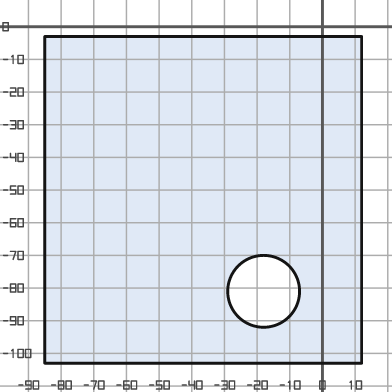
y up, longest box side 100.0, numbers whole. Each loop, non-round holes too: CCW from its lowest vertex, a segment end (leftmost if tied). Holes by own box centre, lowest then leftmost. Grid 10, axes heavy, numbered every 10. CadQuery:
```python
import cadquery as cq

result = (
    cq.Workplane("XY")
    .moveTo(-85.0, -103.0)
    .lineTo(12.0, -103.0)
    .lineTo(12.0, -3.0)
    .lineTo(-85.0, -3.0)
    .close()
    .moveTo(-18.0, -81.0)
    .circle(11.0)
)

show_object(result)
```